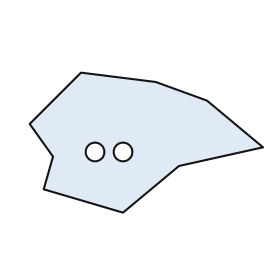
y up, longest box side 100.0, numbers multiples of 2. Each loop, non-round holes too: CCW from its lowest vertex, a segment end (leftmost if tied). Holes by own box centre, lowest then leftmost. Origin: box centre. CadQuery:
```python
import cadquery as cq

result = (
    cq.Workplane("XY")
    .moveTo(-10.0, -30.0)
    .lineTo(14.0, -10.0)
    .lineTo(50.0, -2.0)
    .lineTo(26.0, 18.0)
    .lineTo(4.0, 26.0)
    .lineTo(-28.0, 30.0)
    .lineTo(-50.0, 8.0)
    .lineTo(-40.0, -6.0)
    .lineTo(-44.0, -20.0)
    .close()
    .moveTo(-22.0, -4.0)
    .circle(4.0)
    .moveTo(-10.0, -4.0)
    .circle(4.0)
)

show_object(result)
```